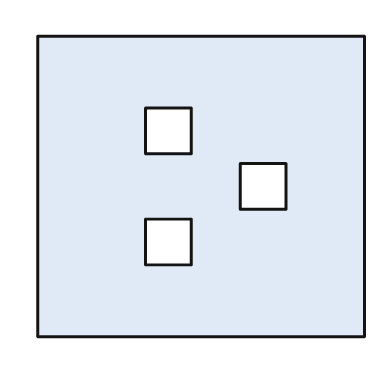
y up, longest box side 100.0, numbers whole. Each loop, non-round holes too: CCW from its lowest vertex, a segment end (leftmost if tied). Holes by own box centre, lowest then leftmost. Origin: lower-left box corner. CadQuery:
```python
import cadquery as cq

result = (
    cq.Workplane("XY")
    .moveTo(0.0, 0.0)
    .lineTo(100.0, 0.0)
    .lineTo(100.0, 92.0)
    .lineTo(0.0, 92.0)
    .close()
    .moveTo(33.0, 22.0)
    .lineTo(47.0, 22.0)
    .lineTo(47.0, 36.0)
    .lineTo(33.0, 36.0)
    .close()
    .moveTo(62.0, 39.0)
    .lineTo(76.0, 39.0)
    .lineTo(76.0, 53.0)
    .lineTo(62.0, 53.0)
    .close()
    .moveTo(33.0, 56.0)
    .lineTo(47.0, 56.0)
    .lineTo(47.0, 70.0)
    .lineTo(33.0, 70.0)
    .close()
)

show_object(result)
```